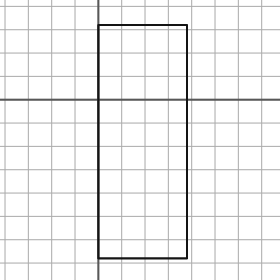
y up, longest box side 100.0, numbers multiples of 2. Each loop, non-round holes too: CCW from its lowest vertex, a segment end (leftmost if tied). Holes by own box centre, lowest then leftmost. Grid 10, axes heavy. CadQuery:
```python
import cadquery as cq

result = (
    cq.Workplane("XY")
    .moveTo(0.0, -68.0)
    .lineTo(38.0, -68.0)
    .lineTo(38.0, 32.0)
    .lineTo(0.0, 32.0)
    .close()
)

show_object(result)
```